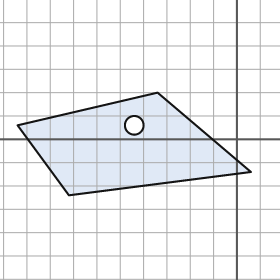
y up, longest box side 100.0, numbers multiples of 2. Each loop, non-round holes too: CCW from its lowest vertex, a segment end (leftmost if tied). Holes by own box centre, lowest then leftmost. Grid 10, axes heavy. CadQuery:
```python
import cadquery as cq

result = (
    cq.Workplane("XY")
    .moveTo(-72.0, -24.0)
    .lineTo(6.0, -14.0)
    .lineTo(-34.0, 20.0)
    .lineTo(-94.0, 6.0)
    .close()
    .moveTo(-44.0, 6.0)
    .circle(4.0)
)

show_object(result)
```